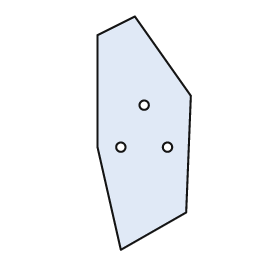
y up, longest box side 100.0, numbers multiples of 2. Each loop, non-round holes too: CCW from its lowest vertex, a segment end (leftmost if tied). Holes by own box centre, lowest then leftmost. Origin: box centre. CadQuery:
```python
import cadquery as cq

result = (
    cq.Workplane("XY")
    .moveTo(-10.0, -50.0)
    .lineTo(18.0, -34.0)
    .lineTo(20.0, 16.0)
    .lineTo(-4.0, 50.0)
    .lineTo(-20.0, 42.0)
    .lineTo(-20.0, -6.0)
    .close()
    .moveTo(-10.0, -6.0)
    .circle(2.0)
    .moveTo(10.0, -6.0)
    .circle(2.0)
    .moveTo(0.0, 12.0)
    .circle(2.0)
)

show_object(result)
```